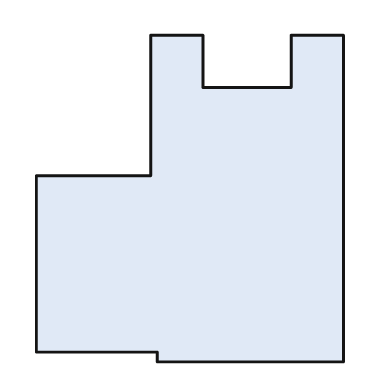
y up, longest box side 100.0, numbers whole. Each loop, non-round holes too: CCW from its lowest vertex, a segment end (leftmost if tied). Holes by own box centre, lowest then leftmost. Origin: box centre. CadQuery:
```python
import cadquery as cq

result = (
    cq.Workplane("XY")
    .moveTo(-10.0, -50.0)
    .lineTo(47.0, -50.0)
    .lineTo(47.0, 50.0)
    .lineTo(31.0, 50.0)
    .lineTo(31.0, 34.0)
    .lineTo(4.0, 34.0)
    .lineTo(4.0, 50.0)
    .lineTo(-12.0, 50.0)
    .lineTo(-12.0, 7.0)
    .lineTo(-47.0, 7.0)
    .lineTo(-47.0, -47.0)
    .lineTo(-10.0, -47.0)
    .close()
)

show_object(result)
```